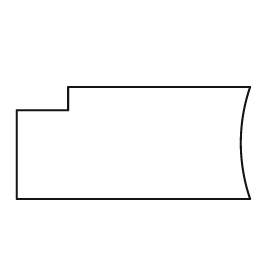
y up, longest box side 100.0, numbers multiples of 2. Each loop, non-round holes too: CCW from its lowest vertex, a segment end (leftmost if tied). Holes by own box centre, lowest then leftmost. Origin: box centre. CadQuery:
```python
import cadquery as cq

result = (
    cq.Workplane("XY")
    .moveTo(-50.0, -24.0)
    .lineTo(50.0, -24.0)
    .threePointArc((46.0, 0.0), (50.0, 24.0))
    .lineTo(-28.0, 24.0)
    .lineTo(-28.0, 14.0)
    .lineTo(-50.0, 14.0)
    .close()
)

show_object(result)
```